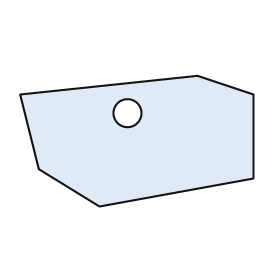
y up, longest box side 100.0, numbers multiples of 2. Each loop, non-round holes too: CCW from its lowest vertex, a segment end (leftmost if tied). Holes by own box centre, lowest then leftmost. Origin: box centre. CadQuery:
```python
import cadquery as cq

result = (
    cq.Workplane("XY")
    .moveTo(-16.0, -28.0)
    .lineTo(50.0, -16.0)
    .lineTo(50.0, 20.0)
    .lineTo(26.0, 28.0)
    .lineTo(-50.0, 20.0)
    .lineTo(-42.0, -12.0)
    .close()
    .moveTo(-4.0, 12.0)
    .circle(6.0)
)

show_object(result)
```